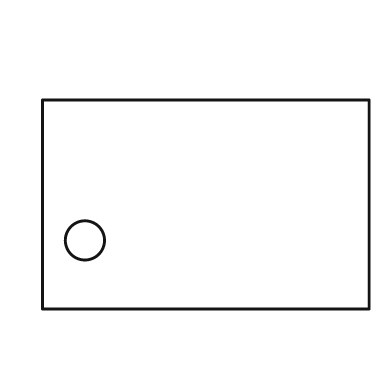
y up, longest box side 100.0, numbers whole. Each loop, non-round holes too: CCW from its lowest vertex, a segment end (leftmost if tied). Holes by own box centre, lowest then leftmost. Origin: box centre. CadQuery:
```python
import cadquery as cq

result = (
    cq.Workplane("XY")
    .moveTo(-50.0, -32.0)
    .lineTo(50.0, -32.0)
    .lineTo(50.0, 32.0)
    .lineTo(-50.0, 32.0)
    .close()
    .moveTo(-37.0, -11.0)
    .circle(6.0)
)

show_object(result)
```